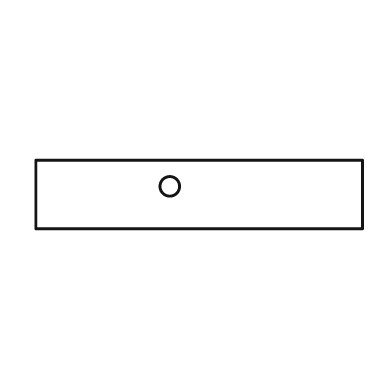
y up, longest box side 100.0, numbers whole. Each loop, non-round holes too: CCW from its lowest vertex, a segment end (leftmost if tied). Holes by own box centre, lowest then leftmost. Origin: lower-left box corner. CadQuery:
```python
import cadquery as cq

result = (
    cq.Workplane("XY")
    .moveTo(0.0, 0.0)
    .lineTo(100.0, 0.0)
    .lineTo(100.0, 21.0)
    .lineTo(0.0, 21.0)
    .close()
    .moveTo(41.0, 13.0)
    .circle(3.0)
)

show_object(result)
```